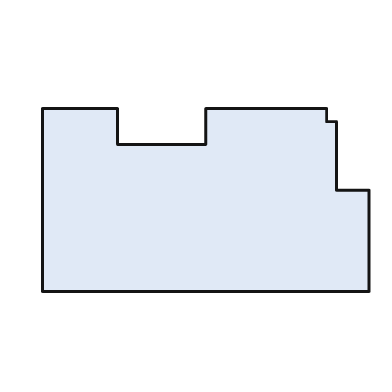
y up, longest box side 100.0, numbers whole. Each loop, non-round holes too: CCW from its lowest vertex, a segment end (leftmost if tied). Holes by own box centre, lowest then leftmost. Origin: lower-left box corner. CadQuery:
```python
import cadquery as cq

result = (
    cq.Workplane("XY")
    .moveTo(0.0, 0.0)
    .lineTo(100.0, 0.0)
    .lineTo(100.0, 31.0)
    .lineTo(90.0, 31.0)
    .lineTo(90.0, 52.0)
    .lineTo(87.0, 52.0)
    .lineTo(87.0, 56.0)
    .lineTo(50.0, 56.0)
    .lineTo(50.0, 45.0)
    .lineTo(23.0, 45.0)
    .lineTo(23.0, 56.0)
    .lineTo(0.0, 56.0)
    .close()
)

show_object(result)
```